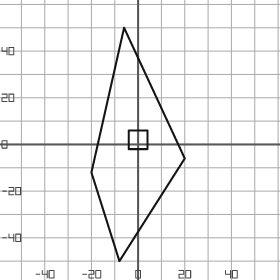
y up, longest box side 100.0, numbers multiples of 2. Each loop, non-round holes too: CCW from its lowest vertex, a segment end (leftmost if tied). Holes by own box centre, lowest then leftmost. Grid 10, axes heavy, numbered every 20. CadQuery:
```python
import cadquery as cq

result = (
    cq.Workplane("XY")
    .moveTo(-8.0, -50.0)
    .lineTo(20.0, -6.0)
    .lineTo(-6.0, 50.0)
    .lineTo(-20.0, -12.0)
    .close()
    .moveTo(-4.0, -2.0)
    .lineTo(4.0, -2.0)
    .lineTo(4.0, 6.0)
    .lineTo(-4.0, 6.0)
    .close()
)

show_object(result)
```